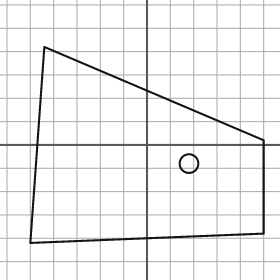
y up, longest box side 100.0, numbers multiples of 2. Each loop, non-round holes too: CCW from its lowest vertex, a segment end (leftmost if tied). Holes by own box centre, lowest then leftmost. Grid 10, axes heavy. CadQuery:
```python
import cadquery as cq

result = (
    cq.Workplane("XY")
    .moveTo(-50.0, -42.0)
    .lineTo(50.0, -38.0)
    .lineTo(50.0, 2.0)
    .lineTo(-44.0, 42.0)
    .close()
    .moveTo(18.0, -8.0)
    .circle(4.0)
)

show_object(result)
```